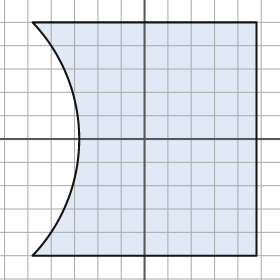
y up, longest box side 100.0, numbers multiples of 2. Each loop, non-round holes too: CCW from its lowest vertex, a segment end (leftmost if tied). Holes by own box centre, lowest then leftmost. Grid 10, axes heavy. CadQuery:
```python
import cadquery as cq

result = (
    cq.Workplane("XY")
    .moveTo(-48.0, -50.0)
    .lineTo(48.0, -50.0)
    .lineTo(48.0, 50.0)
    .lineTo(-48.0, 50.0)
    .threePointArc((-28.0, 0.0), (-48.0, -50.0))
    .close()
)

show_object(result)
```